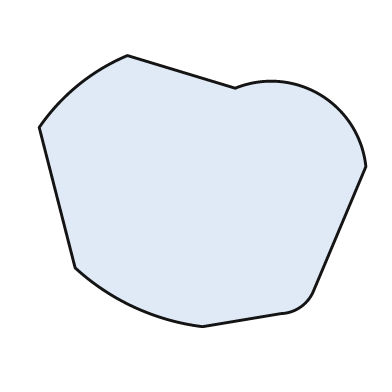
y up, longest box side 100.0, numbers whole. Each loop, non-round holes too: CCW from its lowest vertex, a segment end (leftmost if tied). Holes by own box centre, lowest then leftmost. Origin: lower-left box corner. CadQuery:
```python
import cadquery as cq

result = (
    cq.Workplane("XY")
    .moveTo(50.0, 0.0)
    .lineTo(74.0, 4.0)
    .threePointArc((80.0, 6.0), (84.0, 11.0))
    .lineTo(100.0, 49.0)
    .threePointArc((86.0, 71.0), (60.0, 73.0))
    .lineTo(27.0, 83.0)
    .threePointArc((12.0, 74.0), (0.0, 61.0))
    .lineTo(11.0, 18.0)
    .threePointArc((29.0, 6.0), (50.0, 0.0))
    .close()
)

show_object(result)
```